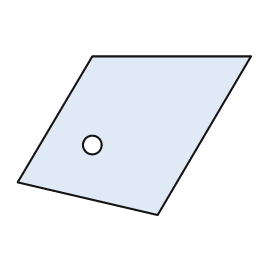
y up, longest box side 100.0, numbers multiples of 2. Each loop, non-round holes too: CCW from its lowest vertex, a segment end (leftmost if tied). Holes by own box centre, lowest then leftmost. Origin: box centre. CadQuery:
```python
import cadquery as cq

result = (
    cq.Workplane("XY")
    .moveTo(10.0, -34.0)
    .lineTo(50.0, 34.0)
    .lineTo(-18.0, 34.0)
    .lineTo(-50.0, -20.0)
    .close()
    .moveTo(-18.0, -4.0)
    .circle(4.0)
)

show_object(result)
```